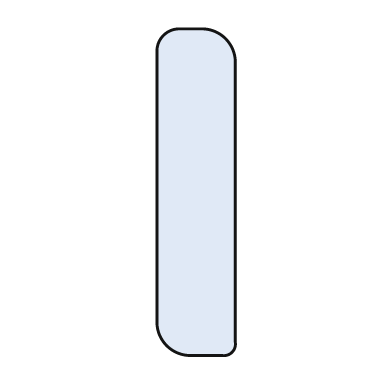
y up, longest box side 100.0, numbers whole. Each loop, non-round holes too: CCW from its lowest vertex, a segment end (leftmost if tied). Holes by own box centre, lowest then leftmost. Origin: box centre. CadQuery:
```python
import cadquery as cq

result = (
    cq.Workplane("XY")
    .moveTo(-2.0, -50.0)
    .lineTo(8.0, -50.0)
    .threePointArc((11.0, -49.0), (12.0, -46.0))
    .lineTo(12.0, 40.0)
    .threePointArc((9.0, 47.0), (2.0, 50.0))
    .lineTo(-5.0, 50.0)
    .threePointArc((-10.0, 48.0), (-12.0, 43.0))
    .lineTo(-12.0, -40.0)
    .threePointArc((-9.0, -47.0), (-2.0, -50.0))
    .close()
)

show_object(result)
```